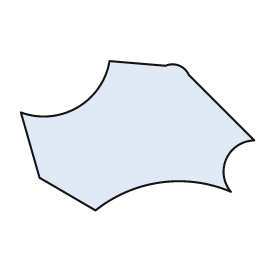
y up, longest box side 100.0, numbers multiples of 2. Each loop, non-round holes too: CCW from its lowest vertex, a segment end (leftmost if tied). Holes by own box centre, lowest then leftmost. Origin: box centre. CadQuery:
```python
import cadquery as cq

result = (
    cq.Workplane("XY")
    .moveTo(-18.0, -32.0)
    .threePointArc((10.0, -20.0), (40.0, -24.0))
    .threePointArc((38.0, -10.0), (50.0, -2.0))
    .lineTo(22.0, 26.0)
    .threePointArc((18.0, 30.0), (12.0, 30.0))
    .lineTo(-12.0, 32.0)
    .threePointArc((-26.0, 12.0), (-50.0, 10.0))
    .lineTo(-42.0, -18.0)
    .close()
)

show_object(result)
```